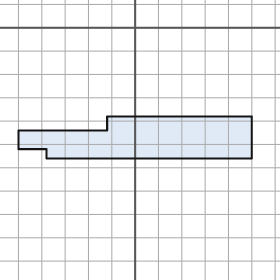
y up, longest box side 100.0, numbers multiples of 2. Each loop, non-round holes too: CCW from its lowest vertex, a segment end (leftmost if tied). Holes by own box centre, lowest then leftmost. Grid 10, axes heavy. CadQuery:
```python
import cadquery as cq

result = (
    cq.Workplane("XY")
    .moveTo(-38.0, -56.0)
    .lineTo(50.0, -56.0)
    .lineTo(50.0, -38.0)
    .lineTo(-12.0, -38.0)
    .lineTo(-12.0, -44.0)
    .lineTo(-50.0, -44.0)
    .lineTo(-50.0, -52.0)
    .lineTo(-38.0, -52.0)
    .close()
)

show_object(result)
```